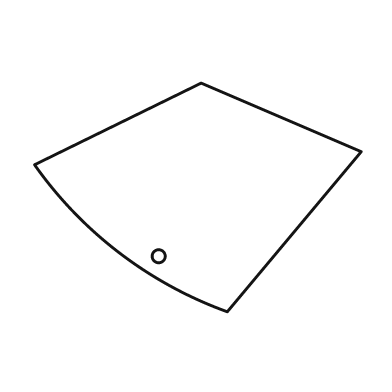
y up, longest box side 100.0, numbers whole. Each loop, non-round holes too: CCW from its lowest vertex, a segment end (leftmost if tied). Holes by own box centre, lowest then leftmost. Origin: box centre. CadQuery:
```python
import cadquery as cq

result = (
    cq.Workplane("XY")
    .moveTo(9.0, -35.0)
    .lineTo(50.0, 14.0)
    .lineTo(1.0, 35.0)
    .lineTo(-50.0, 10.0)
    .threePointArc((-24.0, -17.0), (9.0, -35.0))
    .close()
    .moveTo(-12.0, -18.0)
    .circle(2.0)
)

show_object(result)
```